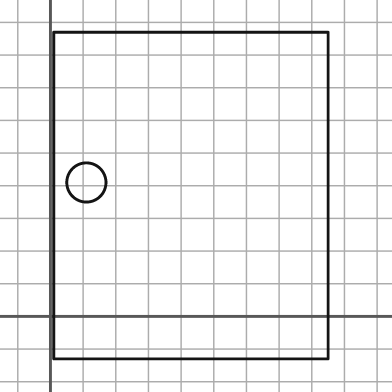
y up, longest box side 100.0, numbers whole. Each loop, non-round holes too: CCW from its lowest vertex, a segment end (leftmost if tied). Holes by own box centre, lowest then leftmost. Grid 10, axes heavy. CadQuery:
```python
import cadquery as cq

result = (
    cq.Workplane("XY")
    .moveTo(1.0, -13.0)
    .lineTo(85.0, -13.0)
    .lineTo(85.0, 87.0)
    .lineTo(1.0, 87.0)
    .close()
    .moveTo(11.0, 41.0)
    .circle(6.0)
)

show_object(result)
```